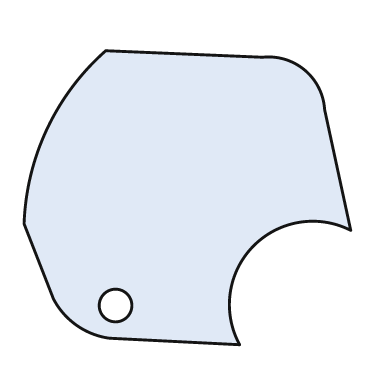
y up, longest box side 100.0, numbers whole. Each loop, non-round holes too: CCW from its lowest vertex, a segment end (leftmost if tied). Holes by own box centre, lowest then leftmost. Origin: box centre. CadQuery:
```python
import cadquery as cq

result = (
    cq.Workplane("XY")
    .moveTo(16.0, -45.0)
    .threePointArc((20.0, -15.0), (50.0, -10.0))
    .lineTo(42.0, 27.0)
    .threePointArc((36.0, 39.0), (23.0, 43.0))
    .lineTo(-25.0, 45.0)
    .threePointArc((-43.0, 21.0), (-50.0, -8.0))
    .lineTo(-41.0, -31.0)
    .threePointArc((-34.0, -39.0), (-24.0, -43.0))
    .close()
    .moveTo(-22.0, -33.0)
    .circle(5.0)
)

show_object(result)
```